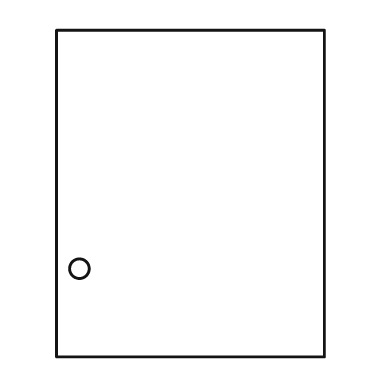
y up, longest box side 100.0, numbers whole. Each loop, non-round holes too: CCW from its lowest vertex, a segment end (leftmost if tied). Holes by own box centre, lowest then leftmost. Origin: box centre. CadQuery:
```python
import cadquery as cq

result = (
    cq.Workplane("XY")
    .moveTo(-41.0, -50.0)
    .lineTo(41.0, -50.0)
    .lineTo(41.0, 50.0)
    .lineTo(-41.0, 50.0)
    .close()
    .moveTo(-34.0, -23.0)
    .circle(3.0)
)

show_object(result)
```